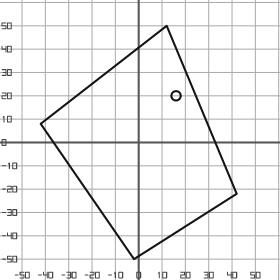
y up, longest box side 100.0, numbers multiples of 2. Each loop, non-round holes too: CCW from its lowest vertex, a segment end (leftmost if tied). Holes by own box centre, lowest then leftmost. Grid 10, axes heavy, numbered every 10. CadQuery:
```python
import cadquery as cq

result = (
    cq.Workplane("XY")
    .moveTo(-2.0, -50.0)
    .lineTo(42.0, -22.0)
    .lineTo(12.0, 50.0)
    .lineTo(-42.0, 8.0)
    .close()
    .moveTo(16.0, 20.0)
    .circle(2.0)
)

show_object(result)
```